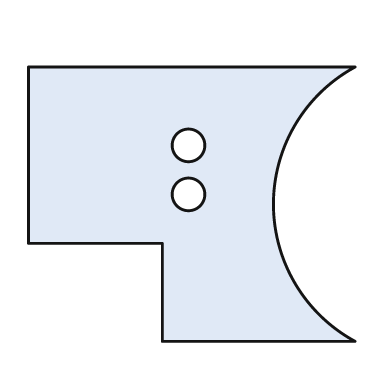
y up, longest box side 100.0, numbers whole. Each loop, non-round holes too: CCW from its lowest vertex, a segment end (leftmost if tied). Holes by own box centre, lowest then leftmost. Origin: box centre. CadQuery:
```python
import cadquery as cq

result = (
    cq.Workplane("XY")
    .moveTo(-9.0, -42.0)
    .lineTo(50.0, -42.0)
    .threePointArc((25.0, 0.0), (50.0, 42.0))
    .lineTo(-50.0, 42.0)
    .lineTo(-50.0, -12.0)
    .lineTo(-9.0, -12.0)
    .close()
    .moveTo(-1.0, 3.0)
    .circle(5.0)
    .moveTo(-1.0, 18.0)
    .circle(5.0)
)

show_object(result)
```